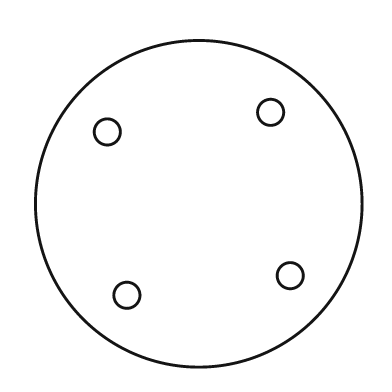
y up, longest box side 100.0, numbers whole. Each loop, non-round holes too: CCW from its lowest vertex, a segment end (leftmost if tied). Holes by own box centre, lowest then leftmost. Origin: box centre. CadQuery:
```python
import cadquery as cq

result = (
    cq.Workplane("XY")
    .moveTo(0.0, 0.0)
    .circle(50.0)
    .moveTo(-22.0, -28.0)
    .circle(4.0)
    .moveTo(28.0, -22.0)
    .circle(4.0)
    .moveTo(-28.0, 22.0)
    .circle(4.0)
    .moveTo(22.0, 28.0)
    .circle(4.0)
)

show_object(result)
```